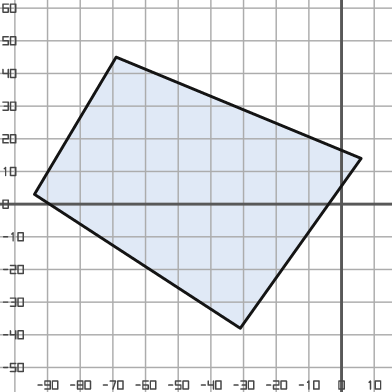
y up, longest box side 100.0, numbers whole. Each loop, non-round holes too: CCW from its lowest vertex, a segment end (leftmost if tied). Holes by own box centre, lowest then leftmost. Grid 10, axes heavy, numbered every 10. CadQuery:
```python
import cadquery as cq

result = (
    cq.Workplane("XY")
    .moveTo(-31.0, -38.0)
    .lineTo(6.0, 14.0)
    .lineTo(-69.0, 45.0)
    .lineTo(-94.0, 3.0)
    .close()
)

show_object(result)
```